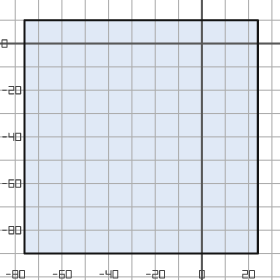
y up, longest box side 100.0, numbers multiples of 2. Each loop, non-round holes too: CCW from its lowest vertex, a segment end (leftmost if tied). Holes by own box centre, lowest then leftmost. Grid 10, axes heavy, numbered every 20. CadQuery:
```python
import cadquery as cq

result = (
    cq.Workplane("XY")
    .moveTo(-76.0, -90.0)
    .lineTo(24.0, -90.0)
    .lineTo(24.0, 10.0)
    .lineTo(-76.0, 10.0)
    .close()
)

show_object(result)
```